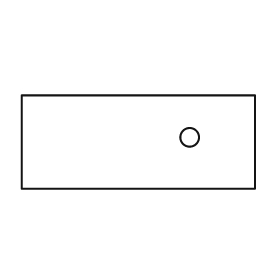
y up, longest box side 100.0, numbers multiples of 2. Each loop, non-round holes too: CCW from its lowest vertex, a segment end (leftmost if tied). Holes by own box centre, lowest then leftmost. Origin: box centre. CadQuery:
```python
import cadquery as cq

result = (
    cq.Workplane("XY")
    .moveTo(-50.0, -20.0)
    .lineTo(50.0, -20.0)
    .lineTo(50.0, 20.0)
    .lineTo(-50.0, 20.0)
    .close()
    .moveTo(22.0, 2.0)
    .circle(4.0)
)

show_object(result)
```